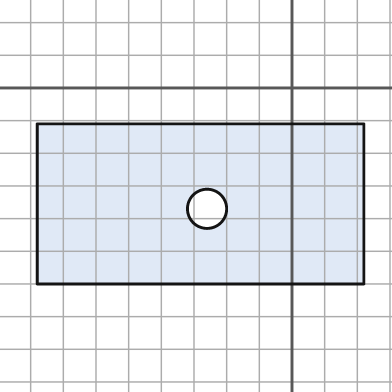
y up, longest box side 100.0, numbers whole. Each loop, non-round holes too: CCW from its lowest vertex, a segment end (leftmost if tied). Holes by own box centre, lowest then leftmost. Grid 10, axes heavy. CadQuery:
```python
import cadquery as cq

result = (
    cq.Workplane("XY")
    .moveTo(-78.0, -60.0)
    .lineTo(22.0, -60.0)
    .lineTo(22.0, -11.0)
    .lineTo(-78.0, -11.0)
    .close()
    .moveTo(-26.0, -37.0)
    .circle(6.0)
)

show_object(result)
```